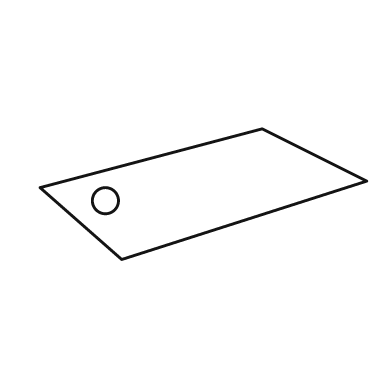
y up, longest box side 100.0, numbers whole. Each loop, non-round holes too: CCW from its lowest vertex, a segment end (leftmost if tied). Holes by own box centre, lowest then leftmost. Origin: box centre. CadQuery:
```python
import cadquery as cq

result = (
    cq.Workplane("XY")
    .moveTo(-25.0, -20.0)
    .lineTo(50.0, 4.0)
    .lineTo(18.0, 20.0)
    .lineTo(-50.0, 2.0)
    .close()
    .moveTo(-30.0, -2.0)
    .circle(4.0)
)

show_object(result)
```